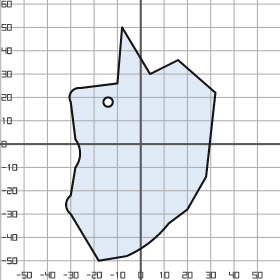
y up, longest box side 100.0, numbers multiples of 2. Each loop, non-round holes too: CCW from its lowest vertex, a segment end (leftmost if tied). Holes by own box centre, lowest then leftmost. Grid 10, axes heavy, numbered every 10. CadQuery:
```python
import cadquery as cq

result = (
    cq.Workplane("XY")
    .moveTo(-18.0, -50.0)
    .lineTo(-6.0, -48.0)
    .threePointArc((4.0, -42.0), (12.0, -34.0))
    .lineTo(20.0, -28.0)
    .lineTo(28.0, -14.0)
    .lineTo(32.0, 22.0)
    .lineTo(16.0, 36.0)
    .lineTo(4.0, 30.0)
    .lineTo(-8.0, 50.0)
    .lineTo(-10.0, 26.0)
    .lineTo(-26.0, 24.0)
    .threePointArc((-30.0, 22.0), (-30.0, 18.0))
    .lineTo(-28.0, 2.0)
    .threePointArc((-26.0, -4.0), (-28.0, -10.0))
    .lineTo(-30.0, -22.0)
    .threePointArc((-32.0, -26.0), (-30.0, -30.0))
    .close()
    .moveTo(-14.0, 18.0)
    .circle(2.0)
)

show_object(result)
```